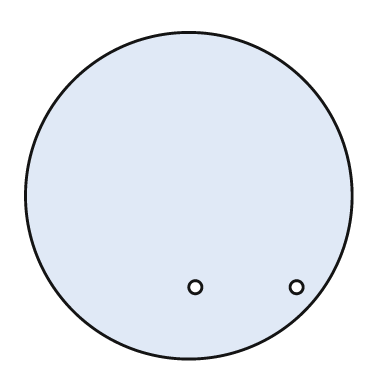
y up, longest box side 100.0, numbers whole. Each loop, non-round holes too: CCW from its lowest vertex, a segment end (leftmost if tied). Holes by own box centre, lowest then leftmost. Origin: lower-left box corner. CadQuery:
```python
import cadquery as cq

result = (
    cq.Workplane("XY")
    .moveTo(50.0, 50.0)
    .circle(50.0)
    .moveTo(52.0, 22.0)
    .circle(2.0)
    .moveTo(83.0, 22.0)
    .circle(2.0)
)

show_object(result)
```